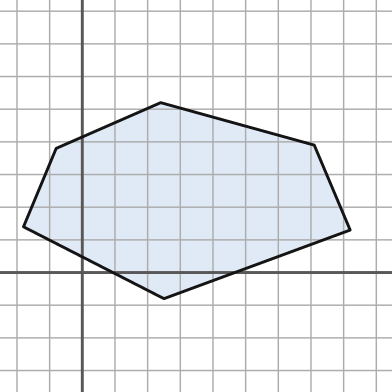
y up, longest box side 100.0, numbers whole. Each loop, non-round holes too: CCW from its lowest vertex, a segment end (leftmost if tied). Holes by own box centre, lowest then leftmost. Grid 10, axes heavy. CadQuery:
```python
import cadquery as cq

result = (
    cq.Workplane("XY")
    .moveTo(25.0, -8.0)
    .lineTo(82.0, 13.0)
    .lineTo(71.0, 39.0)
    .lineTo(24.0, 52.0)
    .lineTo(-8.0, 38.0)
    .lineTo(-18.0, 14.0)
    .close()
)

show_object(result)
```